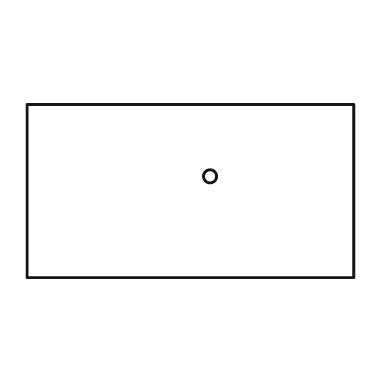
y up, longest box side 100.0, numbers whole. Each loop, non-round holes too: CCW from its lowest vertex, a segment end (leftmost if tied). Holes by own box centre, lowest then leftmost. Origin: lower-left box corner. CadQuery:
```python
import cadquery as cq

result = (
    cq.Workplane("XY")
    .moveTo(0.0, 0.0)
    .lineTo(100.0, 0.0)
    .lineTo(100.0, 53.0)
    .lineTo(0.0, 53.0)
    .close()
    .moveTo(56.0, 31.0)
    .circle(2.0)
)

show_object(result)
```